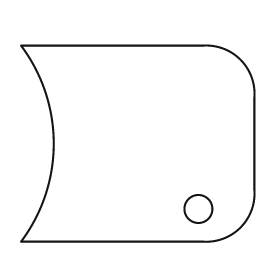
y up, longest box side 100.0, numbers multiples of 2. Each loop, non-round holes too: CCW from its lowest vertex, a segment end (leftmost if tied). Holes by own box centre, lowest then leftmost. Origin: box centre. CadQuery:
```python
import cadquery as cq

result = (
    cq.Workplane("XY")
    .moveTo(-50.0, -42.0)
    .lineTo(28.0, -42.0)
    .threePointArc((44.0, -36.0), (50.0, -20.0))
    .lineTo(50.0, 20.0)
    .threePointArc((44.0, 36.0), (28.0, 42.0))
    .lineTo(-50.0, 42.0)
    .threePointArc((-36.0, 0.0), (-50.0, -42.0))
    .close()
    .moveTo(26.0, -28.0)
    .circle(6.0)
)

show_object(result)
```